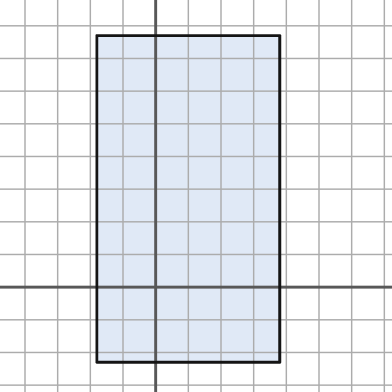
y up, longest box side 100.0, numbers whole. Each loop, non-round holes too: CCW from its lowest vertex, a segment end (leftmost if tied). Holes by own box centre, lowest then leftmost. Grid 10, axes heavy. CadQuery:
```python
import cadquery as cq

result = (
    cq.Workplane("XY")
    .moveTo(-18.0, -23.0)
    .lineTo(38.0, -23.0)
    .lineTo(38.0, 77.0)
    .lineTo(-18.0, 77.0)
    .close()
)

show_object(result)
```